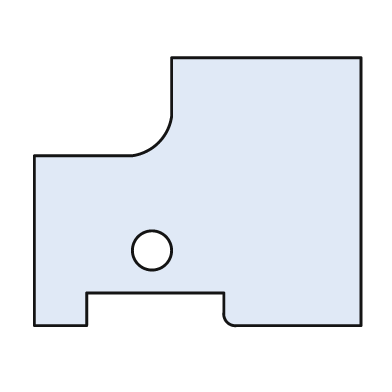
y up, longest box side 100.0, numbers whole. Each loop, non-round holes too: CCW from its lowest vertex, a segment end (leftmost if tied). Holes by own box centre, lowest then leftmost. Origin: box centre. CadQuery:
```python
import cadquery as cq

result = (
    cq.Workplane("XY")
    .moveTo(-50.0, -41.0)
    .lineTo(-34.0, -41.0)
    .lineTo(-34.0, -31.0)
    .lineTo(8.0, -31.0)
    .lineTo(8.0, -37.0)
    .threePointArc((9.0, -40.0), (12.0, -41.0))
    .lineTo(50.0, -41.0)
    .lineTo(50.0, 41.0)
    .lineTo(-8.0, 41.0)
    .lineTo(-8.0, 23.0)
    .threePointArc((-12.0, 15.0), (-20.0, 11.0))
    .lineTo(-50.0, 11.0)
    .close()
    .moveTo(-14.0, -18.0)
    .circle(6.0)
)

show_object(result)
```